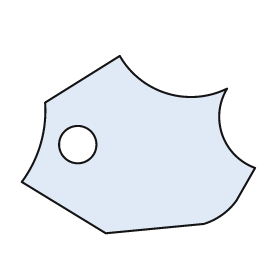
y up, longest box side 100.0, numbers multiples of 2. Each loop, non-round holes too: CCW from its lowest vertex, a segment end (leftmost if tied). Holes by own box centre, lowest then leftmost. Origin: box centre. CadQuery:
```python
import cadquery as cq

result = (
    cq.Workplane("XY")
    .moveTo(-14.0, -38.0)
    .lineTo(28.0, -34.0)
    .threePointArc((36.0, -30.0), (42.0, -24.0))
    .lineTo(50.0, -10.0)
    .threePointArc((36.0, 4.0), (38.0, 24.0))
    .threePointArc((12.0, 22.0), (-8.0, 38.0))
    .lineTo(-40.0, 18.0)
    .threePointArc((-42.0, 0.0), (-50.0, -16.0))
    .close()
    .moveTo(-26.0, 0.0)
    .circle(8.0)
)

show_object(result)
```